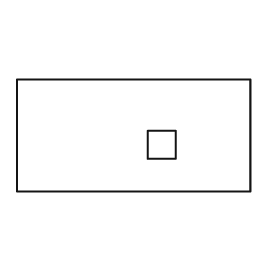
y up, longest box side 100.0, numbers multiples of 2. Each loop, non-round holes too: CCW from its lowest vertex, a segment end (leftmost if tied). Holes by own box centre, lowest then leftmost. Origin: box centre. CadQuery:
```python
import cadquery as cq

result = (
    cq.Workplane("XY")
    .moveTo(-50.0, -24.0)
    .lineTo(50.0, -24.0)
    .lineTo(50.0, 24.0)
    .lineTo(-50.0, 24.0)
    .close()
    .moveTo(6.0, -10.0)
    .lineTo(18.0, -10.0)
    .lineTo(18.0, 2.0)
    .lineTo(6.0, 2.0)
    .close()
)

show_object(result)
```